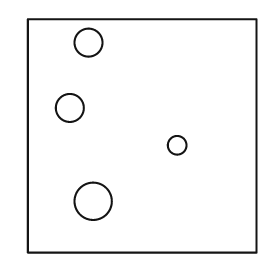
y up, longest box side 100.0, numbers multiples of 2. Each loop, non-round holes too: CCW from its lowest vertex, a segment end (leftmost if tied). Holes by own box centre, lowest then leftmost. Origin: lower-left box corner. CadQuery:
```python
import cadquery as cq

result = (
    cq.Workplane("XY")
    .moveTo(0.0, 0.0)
    .lineTo(98.0, 0.0)
    .lineTo(98.0, 100.0)
    .lineTo(0.0, 100.0)
    .close()
    .moveTo(28.0, 22.0)
    .circle(8.0)
    .moveTo(64.0, 46.0)
    .circle(4.0)
    .moveTo(18.0, 62.0)
    .circle(6.0)
    .moveTo(26.0, 90.0)
    .circle(6.0)
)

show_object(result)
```